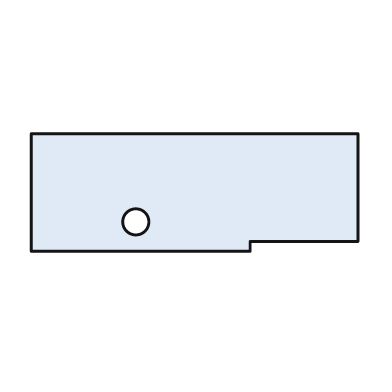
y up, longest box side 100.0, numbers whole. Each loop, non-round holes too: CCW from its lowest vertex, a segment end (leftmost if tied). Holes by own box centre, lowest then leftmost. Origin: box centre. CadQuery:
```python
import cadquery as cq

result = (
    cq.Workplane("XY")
    .moveTo(-50.0, -18.0)
    .lineTo(17.0, -18.0)
    .lineTo(17.0, -15.0)
    .lineTo(50.0, -15.0)
    .lineTo(50.0, 18.0)
    .lineTo(-50.0, 18.0)
    .close()
    .moveTo(-18.0, -9.0)
    .circle(4.0)
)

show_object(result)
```